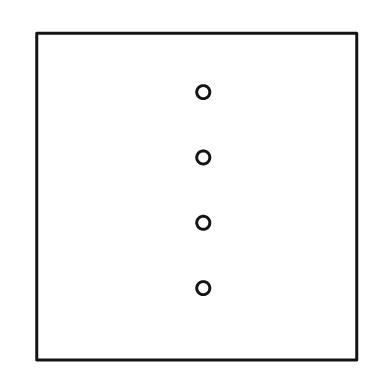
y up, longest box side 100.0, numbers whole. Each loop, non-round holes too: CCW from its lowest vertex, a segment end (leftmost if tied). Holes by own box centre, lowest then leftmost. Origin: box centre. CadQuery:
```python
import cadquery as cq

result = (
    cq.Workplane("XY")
    .moveTo(-49.0, -50.0)
    .lineTo(49.0, -50.0)
    .lineTo(49.0, 50.0)
    .lineTo(-49.0, 50.0)
    .close()
    .moveTo(2.0, -28.0)
    .circle(2.0)
    .moveTo(2.0, -8.0)
    .circle(2.0)
    .moveTo(2.0, 12.0)
    .circle(2.0)
    .moveTo(2.0, 32.0)
    .circle(2.0)
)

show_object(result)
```